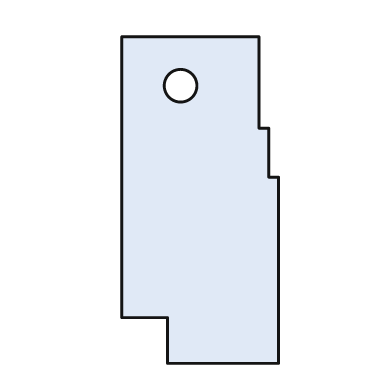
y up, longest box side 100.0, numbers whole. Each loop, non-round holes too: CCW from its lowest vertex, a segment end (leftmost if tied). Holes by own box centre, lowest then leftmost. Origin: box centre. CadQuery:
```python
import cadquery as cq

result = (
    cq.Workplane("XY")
    .moveTo(-10.0, -50.0)
    .lineTo(24.0, -50.0)
    .lineTo(24.0, 7.0)
    .lineTo(21.0, 7.0)
    .lineTo(21.0, 22.0)
    .lineTo(18.0, 22.0)
    .lineTo(18.0, 50.0)
    .lineTo(-24.0, 50.0)
    .lineTo(-24.0, -36.0)
    .lineTo(-10.0, -36.0)
    .close()
    .moveTo(-6.0, 35.0)
    .circle(5.0)
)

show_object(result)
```